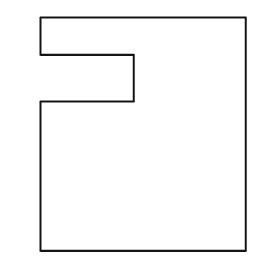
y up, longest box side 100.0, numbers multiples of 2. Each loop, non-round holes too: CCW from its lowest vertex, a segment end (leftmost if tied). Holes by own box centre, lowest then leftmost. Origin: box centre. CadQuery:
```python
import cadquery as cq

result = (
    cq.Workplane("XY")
    .moveTo(-44.0, -50.0)
    .lineTo(44.0, -50.0)
    .lineTo(44.0, 50.0)
    .lineTo(-44.0, 50.0)
    .lineTo(-44.0, 34.0)
    .lineTo(-4.0, 34.0)
    .lineTo(-4.0, 14.0)
    .lineTo(-44.0, 14.0)
    .close()
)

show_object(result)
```